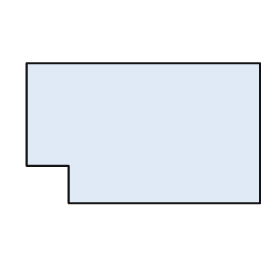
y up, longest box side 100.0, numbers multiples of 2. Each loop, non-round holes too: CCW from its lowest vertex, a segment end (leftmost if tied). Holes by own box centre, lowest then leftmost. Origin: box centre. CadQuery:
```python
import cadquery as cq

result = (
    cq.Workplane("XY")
    .moveTo(-32.0, -30.0)
    .lineTo(50.0, -30.0)
    .lineTo(50.0, 30.0)
    .lineTo(-50.0, 30.0)
    .lineTo(-50.0, -14.0)
    .lineTo(-32.0, -14.0)
    .close()
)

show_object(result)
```